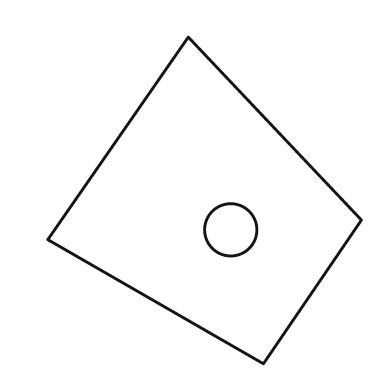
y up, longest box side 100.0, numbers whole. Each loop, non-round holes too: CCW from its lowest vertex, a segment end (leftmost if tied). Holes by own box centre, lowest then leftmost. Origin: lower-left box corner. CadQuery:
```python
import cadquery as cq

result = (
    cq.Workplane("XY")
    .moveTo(66.0, 0.0)
    .lineTo(96.0, 44.0)
    .lineTo(43.0, 100.0)
    .lineTo(0.0, 38.0)
    .close()
    .moveTo(56.0, 41.0)
    .circle(8.0)
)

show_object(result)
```